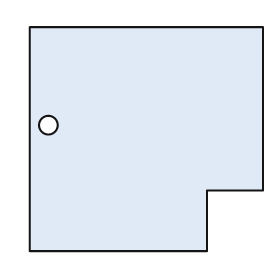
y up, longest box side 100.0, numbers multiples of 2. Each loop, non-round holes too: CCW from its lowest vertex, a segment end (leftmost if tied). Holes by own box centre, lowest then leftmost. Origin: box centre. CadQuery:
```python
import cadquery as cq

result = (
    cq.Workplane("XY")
    .moveTo(-50.0, -48.0)
    .lineTo(26.0, -48.0)
    .lineTo(26.0, -22.0)
    .lineTo(50.0, -22.0)
    .lineTo(50.0, 48.0)
    .lineTo(-50.0, 48.0)
    .close()
    .moveTo(-42.0, 6.0)
    .circle(4.0)
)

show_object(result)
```